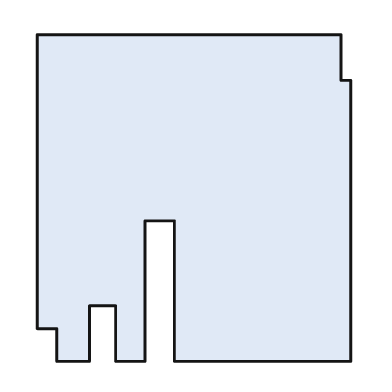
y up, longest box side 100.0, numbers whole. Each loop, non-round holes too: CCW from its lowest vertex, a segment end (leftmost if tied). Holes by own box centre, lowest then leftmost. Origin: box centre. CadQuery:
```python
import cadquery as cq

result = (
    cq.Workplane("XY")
    .moveTo(-42.0, -50.0)
    .lineTo(-32.0, -50.0)
    .lineTo(-32.0, -33.0)
    .lineTo(-24.0, -33.0)
    .lineTo(-24.0, -50.0)
    .lineTo(-15.0, -50.0)
    .lineTo(-15.0, -7.0)
    .lineTo(-6.0, -7.0)
    .lineTo(-6.0, -50.0)
    .lineTo(48.0, -50.0)
    .lineTo(48.0, 36.0)
    .lineTo(45.0, 36.0)
    .lineTo(45.0, 50.0)
    .lineTo(-48.0, 50.0)
    .lineTo(-48.0, -40.0)
    .lineTo(-42.0, -40.0)
    .close()
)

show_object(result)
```